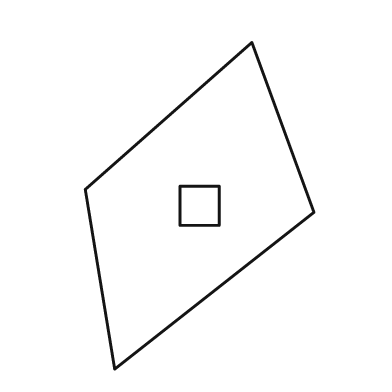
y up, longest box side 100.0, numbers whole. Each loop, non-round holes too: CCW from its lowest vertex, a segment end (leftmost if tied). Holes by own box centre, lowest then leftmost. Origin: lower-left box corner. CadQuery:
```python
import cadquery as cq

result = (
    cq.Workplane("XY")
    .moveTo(9.0, 0.0)
    .lineTo(70.0, 48.0)
    .lineTo(51.0, 100.0)
    .lineTo(0.0, 55.0)
    .close()
    .moveTo(29.0, 44.0)
    .lineTo(41.0, 44.0)
    .lineTo(41.0, 56.0)
    .lineTo(29.0, 56.0)
    .close()
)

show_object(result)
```